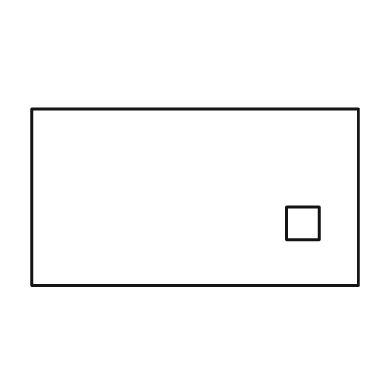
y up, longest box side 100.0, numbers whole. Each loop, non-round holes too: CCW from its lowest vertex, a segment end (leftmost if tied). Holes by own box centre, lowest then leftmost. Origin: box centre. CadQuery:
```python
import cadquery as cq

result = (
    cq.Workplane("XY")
    .moveTo(-50.0, -27.0)
    .lineTo(50.0, -27.0)
    .lineTo(50.0, 27.0)
    .lineTo(-50.0, 27.0)
    .close()
    .moveTo(28.0, -13.0)
    .lineTo(38.0, -13.0)
    .lineTo(38.0, -3.0)
    .lineTo(28.0, -3.0)
    .close()
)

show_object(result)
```